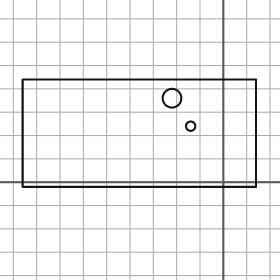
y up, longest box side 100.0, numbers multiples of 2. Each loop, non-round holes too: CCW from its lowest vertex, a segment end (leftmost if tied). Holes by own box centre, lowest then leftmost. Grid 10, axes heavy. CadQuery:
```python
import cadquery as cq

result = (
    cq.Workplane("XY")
    .moveTo(-86.0, -2.0)
    .lineTo(14.0, -2.0)
    .lineTo(14.0, 44.0)
    .lineTo(-86.0, 44.0)
    .close()
    .moveTo(-14.0, 24.0)
    .circle(2.0)
    .moveTo(-22.0, 36.0)
    .circle(4.0)
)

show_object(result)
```